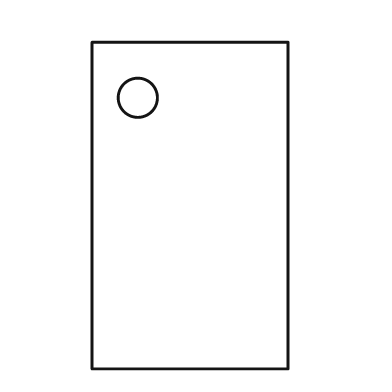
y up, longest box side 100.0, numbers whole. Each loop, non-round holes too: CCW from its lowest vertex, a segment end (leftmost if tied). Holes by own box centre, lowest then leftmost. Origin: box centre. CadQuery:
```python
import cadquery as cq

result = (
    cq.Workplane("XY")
    .moveTo(-30.0, -50.0)
    .lineTo(30.0, -50.0)
    .lineTo(30.0, 50.0)
    .lineTo(-30.0, 50.0)
    .close()
    .moveTo(-16.0, 33.0)
    .circle(6.0)
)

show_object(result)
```